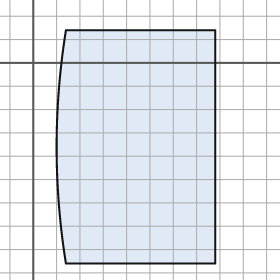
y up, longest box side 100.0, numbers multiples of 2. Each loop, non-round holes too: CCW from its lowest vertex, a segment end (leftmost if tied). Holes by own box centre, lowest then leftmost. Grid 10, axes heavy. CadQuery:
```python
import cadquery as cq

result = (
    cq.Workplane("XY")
    .moveTo(14.0, -86.0)
    .lineTo(78.0, -86.0)
    .lineTo(78.0, 14.0)
    .lineTo(14.0, 14.0)
    .threePointArc((10.0, -36.0), (14.0, -86.0))
    .close()
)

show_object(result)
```